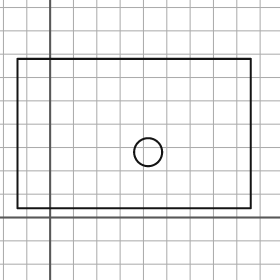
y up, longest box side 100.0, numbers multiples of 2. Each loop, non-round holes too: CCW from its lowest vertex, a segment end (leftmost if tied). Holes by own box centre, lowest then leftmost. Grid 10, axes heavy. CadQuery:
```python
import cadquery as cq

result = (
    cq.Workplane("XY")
    .moveTo(-14.0, 4.0)
    .lineTo(86.0, 4.0)
    .lineTo(86.0, 68.0)
    .lineTo(-14.0, 68.0)
    .close()
    .moveTo(42.0, 28.0)
    .circle(6.0)
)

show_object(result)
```